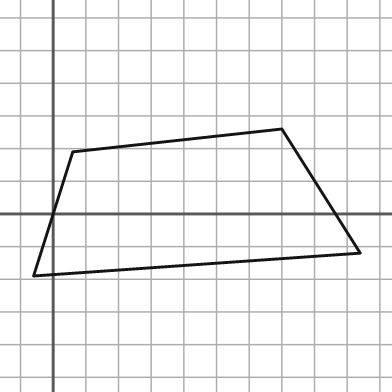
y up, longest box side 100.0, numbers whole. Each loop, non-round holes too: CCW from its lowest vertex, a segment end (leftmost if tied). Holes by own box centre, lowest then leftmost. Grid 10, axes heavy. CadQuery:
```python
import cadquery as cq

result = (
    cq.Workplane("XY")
    .moveTo(-6.0, -19.0)
    .lineTo(94.0, -12.0)
    .lineTo(70.0, 26.0)
    .lineTo(6.0, 19.0)
    .close()
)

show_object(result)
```